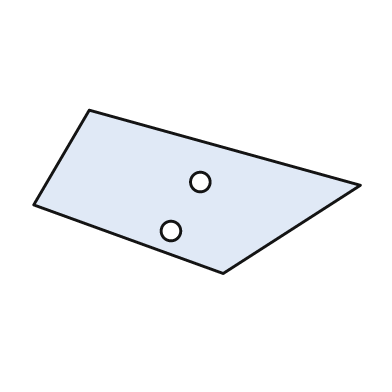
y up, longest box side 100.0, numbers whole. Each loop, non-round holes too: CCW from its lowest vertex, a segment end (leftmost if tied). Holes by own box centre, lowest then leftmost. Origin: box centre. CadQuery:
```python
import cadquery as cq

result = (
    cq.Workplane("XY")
    .moveTo(8.0, -25.0)
    .lineTo(50.0, 2.0)
    .lineTo(-33.0, 25.0)
    .lineTo(-50.0, -4.0)
    .close()
    .moveTo(-8.0, -12.0)
    .circle(3.0)
    .moveTo(1.0, 3.0)
    .circle(3.0)
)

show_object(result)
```